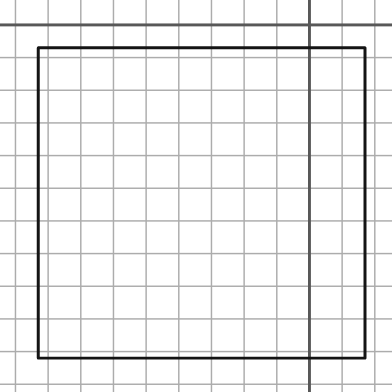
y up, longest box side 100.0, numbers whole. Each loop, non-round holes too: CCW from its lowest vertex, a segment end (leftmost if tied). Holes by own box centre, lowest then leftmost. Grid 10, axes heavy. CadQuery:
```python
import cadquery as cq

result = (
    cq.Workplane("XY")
    .moveTo(-83.0, -102.0)
    .lineTo(17.0, -102.0)
    .lineTo(17.0, -7.0)
    .lineTo(-83.0, -7.0)
    .close()
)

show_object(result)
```